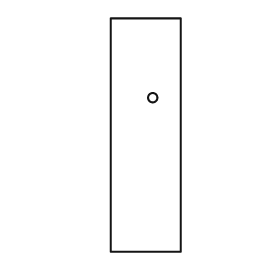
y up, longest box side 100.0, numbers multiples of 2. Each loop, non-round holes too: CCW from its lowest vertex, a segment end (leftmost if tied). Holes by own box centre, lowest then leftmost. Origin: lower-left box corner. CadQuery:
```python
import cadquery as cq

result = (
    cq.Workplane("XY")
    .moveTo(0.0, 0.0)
    .lineTo(30.0, 0.0)
    .lineTo(30.0, 100.0)
    .lineTo(0.0, 100.0)
    .close()
    .moveTo(18.0, 66.0)
    .circle(2.0)
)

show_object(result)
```